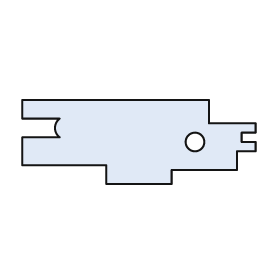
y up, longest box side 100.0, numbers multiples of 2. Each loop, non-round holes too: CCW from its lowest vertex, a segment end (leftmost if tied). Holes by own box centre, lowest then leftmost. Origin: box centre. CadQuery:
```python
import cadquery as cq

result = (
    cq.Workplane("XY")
    .moveTo(-14.0, -18.0)
    .lineTo(14.0, -18.0)
    .lineTo(14.0, -12.0)
    .lineTo(42.0, -12.0)
    .lineTo(42.0, -4.0)
    .lineTo(50.0, -4.0)
    .lineTo(50.0, 0.0)
    .lineTo(44.0, 0.0)
    .lineTo(44.0, 4.0)
    .lineTo(50.0, 4.0)
    .lineTo(50.0, 8.0)
    .lineTo(30.0, 8.0)
    .lineTo(30.0, 18.0)
    .lineTo(-50.0, 18.0)
    .lineTo(-50.0, 10.0)
    .lineTo(-34.0, 10.0)
    .threePointArc((-36.0, 6.0), (-34.0, 2.0))
    .lineTo(-50.0, 2.0)
    .lineTo(-50.0, -10.0)
    .lineTo(-14.0, -10.0)
    .close()
    .moveTo(24.0, 0.0)
    .circle(4.0)
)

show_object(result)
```